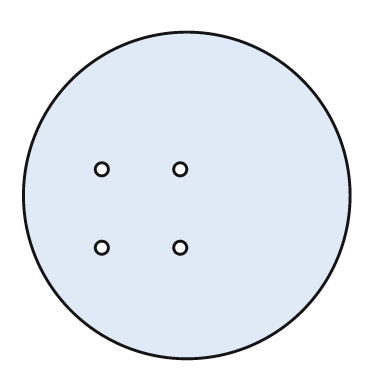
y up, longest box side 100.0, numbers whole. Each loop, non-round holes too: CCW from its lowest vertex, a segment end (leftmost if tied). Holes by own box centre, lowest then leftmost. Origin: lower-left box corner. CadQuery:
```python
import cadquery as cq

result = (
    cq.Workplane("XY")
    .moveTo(50.0, 50.0)
    .circle(50.0)
    .moveTo(24.0, 34.0)
    .circle(2.0)
    .moveTo(48.0, 34.0)
    .circle(2.0)
    .moveTo(24.0, 58.0)
    .circle(2.0)
    .moveTo(48.0, 58.0)
    .circle(2.0)
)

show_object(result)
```